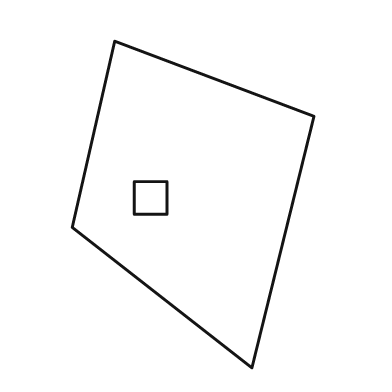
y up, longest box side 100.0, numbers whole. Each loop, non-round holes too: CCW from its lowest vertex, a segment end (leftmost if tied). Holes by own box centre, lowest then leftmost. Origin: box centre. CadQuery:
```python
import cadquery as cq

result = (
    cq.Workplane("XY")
    .moveTo(18.0, -50.0)
    .lineTo(37.0, 27.0)
    .lineTo(-24.0, 50.0)
    .lineTo(-37.0, -7.0)
    .close()
    .moveTo(-18.0, -3.0)
    .lineTo(-8.0, -3.0)
    .lineTo(-8.0, 7.0)
    .lineTo(-18.0, 7.0)
    .close()
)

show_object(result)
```